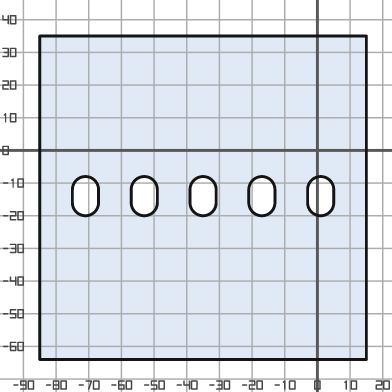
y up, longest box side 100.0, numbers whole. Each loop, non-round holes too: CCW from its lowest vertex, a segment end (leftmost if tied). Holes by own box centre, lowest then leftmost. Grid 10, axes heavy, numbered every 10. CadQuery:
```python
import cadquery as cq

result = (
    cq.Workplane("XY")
    .moveTo(-85.0, -64.0)
    .lineTo(15.0, -64.0)
    .lineTo(15.0, 35.0)
    .lineTo(-85.0, 35.0)
    .close()
    .moveTo(-75.0, -16.0)
    .threePointArc((-71.0, -20.0), (-67.0, -16.0))
    .lineTo(-67.0, -12.0)
    .threePointArc((-71.0, -8.0), (-75.0, -12.0))
    .close()
    .moveTo(-57.0, -16.0)
    .threePointArc((-53.0, -20.0), (-49.0, -16.0))
    .lineTo(-49.0, -12.0)
    .threePointArc((-53.0, -8.0), (-57.0, -12.0))
    .close()
    .moveTo(-39.0, -16.0)
    .threePointArc((-35.0, -20.0), (-31.0, -16.0))
    .lineTo(-31.0, -12.0)
    .threePointArc((-35.0, -8.0), (-39.0, -12.0))
    .close()
    .moveTo(-21.0, -16.0)
    .threePointArc((-17.0, -20.0), (-13.0, -16.0))
    .lineTo(-13.0, -12.0)
    .threePointArc((-17.0, -8.0), (-21.0, -12.0))
    .close()
    .moveTo(-3.0, -16.0)
    .threePointArc((1.0, -20.0), (5.0, -16.0))
    .lineTo(5.0, -12.0)
    .threePointArc((1.0, -8.0), (-3.0, -12.0))
    .close()
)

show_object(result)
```